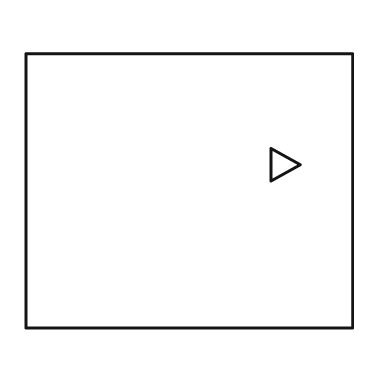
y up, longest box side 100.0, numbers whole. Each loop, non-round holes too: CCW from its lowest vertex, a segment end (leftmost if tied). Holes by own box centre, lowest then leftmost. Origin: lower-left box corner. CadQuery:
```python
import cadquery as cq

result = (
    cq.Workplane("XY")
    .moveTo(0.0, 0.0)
    .lineTo(100.0, 0.0)
    .lineTo(100.0, 84.0)
    .lineTo(0.0, 84.0)
    .close()
    .moveTo(75.0, 45.0)
    .lineTo(84.0, 50.0)
    .lineTo(75.0, 55.0)
    .close()
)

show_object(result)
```